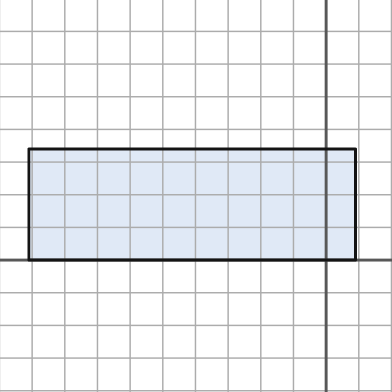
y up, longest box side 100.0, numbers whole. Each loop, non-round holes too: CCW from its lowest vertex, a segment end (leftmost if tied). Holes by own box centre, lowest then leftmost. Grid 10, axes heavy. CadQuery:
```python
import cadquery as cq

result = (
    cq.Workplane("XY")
    .moveTo(-91.0, 0.0)
    .lineTo(9.0, 0.0)
    .lineTo(9.0, 34.0)
    .lineTo(-91.0, 34.0)
    .close()
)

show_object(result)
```